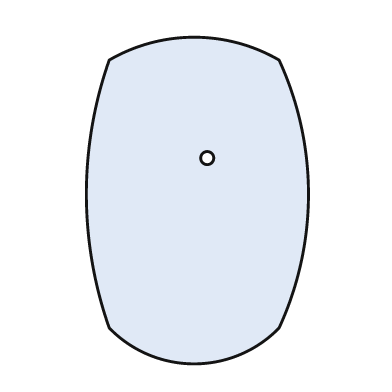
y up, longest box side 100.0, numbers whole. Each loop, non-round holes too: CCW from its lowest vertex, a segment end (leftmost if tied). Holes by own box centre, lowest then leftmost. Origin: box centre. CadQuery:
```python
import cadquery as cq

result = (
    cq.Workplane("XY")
    .moveTo(-27.0, -39.0)
    .threePointArc((-1.0, -50.0), (25.0, -39.0))
    .threePointArc((34.0, 2.0), (25.0, 43.0))
    .threePointArc((-1.0, 50.0), (-27.0, 43.0))
    .threePointArc((-34.0, 2.0), (-27.0, -39.0))
    .close()
    .moveTo(3.0, 13.0)
    .circle(2.0)
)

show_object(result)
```